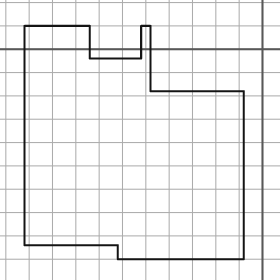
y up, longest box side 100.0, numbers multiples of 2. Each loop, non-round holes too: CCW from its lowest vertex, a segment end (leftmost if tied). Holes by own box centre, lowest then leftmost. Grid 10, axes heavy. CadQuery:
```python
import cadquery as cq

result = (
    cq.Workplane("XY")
    .moveTo(-62.0, -90.0)
    .lineTo(-8.0, -90.0)
    .lineTo(-8.0, -18.0)
    .lineTo(-48.0, -18.0)
    .lineTo(-48.0, 10.0)
    .lineTo(-52.0, 10.0)
    .lineTo(-52.0, -4.0)
    .lineTo(-74.0, -4.0)
    .lineTo(-74.0, 10.0)
    .lineTo(-102.0, 10.0)
    .lineTo(-102.0, -84.0)
    .lineTo(-62.0, -84.0)
    .close()
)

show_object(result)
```